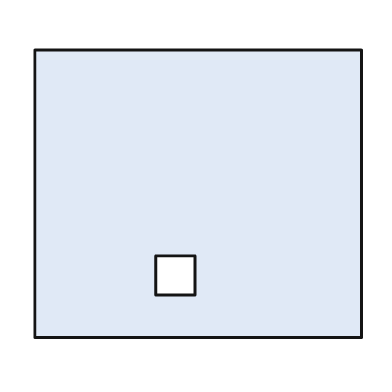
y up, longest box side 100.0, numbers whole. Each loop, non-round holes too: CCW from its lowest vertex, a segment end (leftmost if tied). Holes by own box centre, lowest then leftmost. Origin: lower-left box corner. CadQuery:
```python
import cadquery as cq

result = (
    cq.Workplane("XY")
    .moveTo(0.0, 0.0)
    .lineTo(100.0, 0.0)
    .lineTo(100.0, 88.0)
    .lineTo(0.0, 88.0)
    .close()
    .moveTo(37.0, 13.0)
    .lineTo(49.0, 13.0)
    .lineTo(49.0, 25.0)
    .lineTo(37.0, 25.0)
    .close()
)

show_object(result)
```